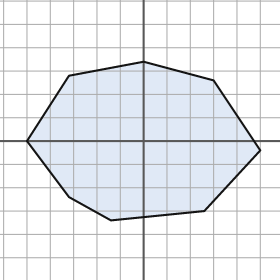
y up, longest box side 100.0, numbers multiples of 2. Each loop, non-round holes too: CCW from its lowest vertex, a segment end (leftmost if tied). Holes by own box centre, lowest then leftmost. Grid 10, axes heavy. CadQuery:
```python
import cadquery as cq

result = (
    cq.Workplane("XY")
    .moveTo(-14.0, -34.0)
    .lineTo(26.0, -30.0)
    .lineTo(50.0, -4.0)
    .lineTo(30.0, 26.0)
    .lineTo(0.0, 34.0)
    .lineTo(-32.0, 28.0)
    .lineTo(-50.0, 0.0)
    .lineTo(-32.0, -24.0)
    .close()
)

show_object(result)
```